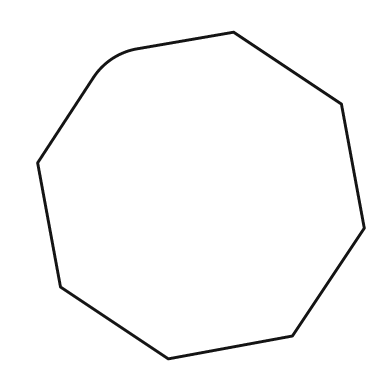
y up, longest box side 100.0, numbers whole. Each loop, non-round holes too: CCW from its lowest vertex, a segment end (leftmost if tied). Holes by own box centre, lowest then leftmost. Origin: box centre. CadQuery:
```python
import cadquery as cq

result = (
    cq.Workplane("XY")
    .moveTo(-10.0, -50.0)
    .lineTo(28.0, -43.0)
    .lineTo(50.0, -10.0)
    .lineTo(43.0, 28.0)
    .lineTo(10.0, 50.0)
    .lineTo(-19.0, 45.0)
    .threePointArc((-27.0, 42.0), (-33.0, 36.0))
    .lineTo(-50.0, 10.0)
    .lineTo(-43.0, -28.0)
    .close()
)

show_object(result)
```